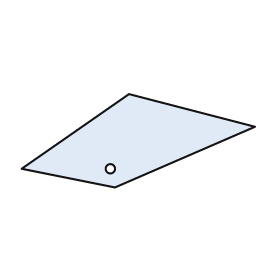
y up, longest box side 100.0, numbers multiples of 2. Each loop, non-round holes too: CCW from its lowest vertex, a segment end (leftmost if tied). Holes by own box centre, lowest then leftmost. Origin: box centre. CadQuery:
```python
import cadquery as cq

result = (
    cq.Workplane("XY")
    .moveTo(-10.0, -20.0)
    .lineTo(50.0, 6.0)
    .lineTo(-4.0, 20.0)
    .lineTo(-50.0, -12.0)
    .close()
    .moveTo(-12.0, -12.0)
    .circle(2.0)
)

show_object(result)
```